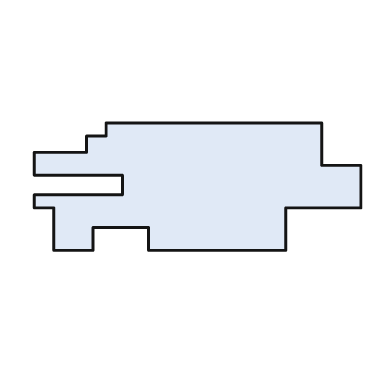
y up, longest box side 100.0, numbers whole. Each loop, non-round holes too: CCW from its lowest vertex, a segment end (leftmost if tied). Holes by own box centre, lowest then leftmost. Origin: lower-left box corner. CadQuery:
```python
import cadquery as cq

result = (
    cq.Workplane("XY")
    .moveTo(6.0, 0.0)
    .lineTo(18.0, 0.0)
    .lineTo(18.0, 7.0)
    .lineTo(35.0, 7.0)
    .lineTo(35.0, 0.0)
    .lineTo(77.0, 0.0)
    .lineTo(77.0, 13.0)
    .lineTo(100.0, 13.0)
    .lineTo(100.0, 26.0)
    .lineTo(88.0, 26.0)
    .lineTo(88.0, 39.0)
    .lineTo(22.0, 39.0)
    .lineTo(22.0, 35.0)
    .lineTo(16.0, 35.0)
    .lineTo(16.0, 30.0)
    .lineTo(0.0, 30.0)
    .lineTo(0.0, 23.0)
    .lineTo(27.0, 23.0)
    .lineTo(27.0, 17.0)
    .lineTo(0.0, 17.0)
    .lineTo(0.0, 13.0)
    .lineTo(6.0, 13.0)
    .close()
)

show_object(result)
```